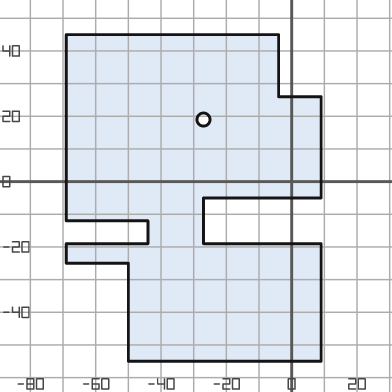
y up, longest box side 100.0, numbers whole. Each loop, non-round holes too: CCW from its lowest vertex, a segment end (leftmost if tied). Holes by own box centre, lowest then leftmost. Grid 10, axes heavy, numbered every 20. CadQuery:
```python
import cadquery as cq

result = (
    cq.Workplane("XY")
    .moveTo(-50.0, -55.0)
    .lineTo(9.0, -55.0)
    .lineTo(9.0, -19.0)
    .lineTo(-27.0, -19.0)
    .lineTo(-27.0, -5.0)
    .lineTo(9.0, -5.0)
    .lineTo(9.0, 26.0)
    .lineTo(-4.0, 26.0)
    .lineTo(-4.0, 45.0)
    .lineTo(-69.0, 45.0)
    .lineTo(-69.0, -12.0)
    .lineTo(-44.0, -12.0)
    .lineTo(-44.0, -19.0)
    .lineTo(-69.0, -19.0)
    .lineTo(-69.0, -25.0)
    .lineTo(-50.0, -25.0)
    .close()
    .moveTo(-27.0, 19.0)
    .circle(2.0)
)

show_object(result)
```